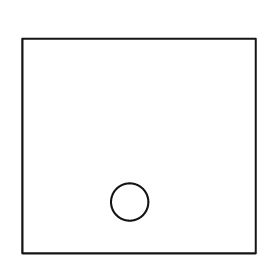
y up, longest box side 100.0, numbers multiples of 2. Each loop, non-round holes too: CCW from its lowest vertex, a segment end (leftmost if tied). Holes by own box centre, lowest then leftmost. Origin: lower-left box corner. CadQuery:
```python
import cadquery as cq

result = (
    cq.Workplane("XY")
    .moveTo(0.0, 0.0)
    .lineTo(100.0, 0.0)
    .lineTo(100.0, 92.0)
    .lineTo(0.0, 92.0)
    .close()
    .moveTo(46.0, 22.0)
    .circle(8.0)
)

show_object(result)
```